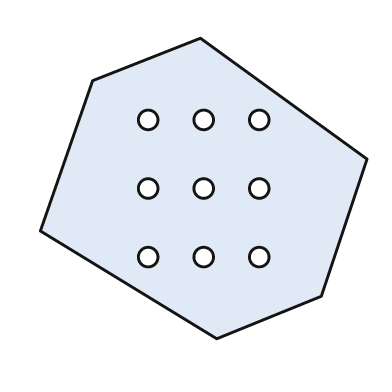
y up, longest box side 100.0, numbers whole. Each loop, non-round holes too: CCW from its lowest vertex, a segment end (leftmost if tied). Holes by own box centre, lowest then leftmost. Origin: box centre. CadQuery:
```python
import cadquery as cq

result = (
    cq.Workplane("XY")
    .moveTo(4.0, -46.0)
    .lineTo(36.0, -33.0)
    .lineTo(50.0, 9.0)
    .lineTo(-1.0, 46.0)
    .lineTo(-34.0, 33.0)
    .lineTo(-50.0, -13.0)
    .close()
    .moveTo(-17.0, -21.0)
    .circle(3.0)
    .moveTo(0.0, -21.0)
    .circle(3.0)
    .moveTo(17.0, -21.0)
    .circle(3.0)
    .moveTo(-17.0, 0.0)
    .circle(3.0)
    .moveTo(0.0, 0.0)
    .circle(3.0)
    .moveTo(17.0, 0.0)
    .circle(3.0)
    .moveTo(-17.0, 21.0)
    .circle(3.0)
    .moveTo(0.0, 21.0)
    .circle(3.0)
    .moveTo(17.0, 21.0)
    .circle(3.0)
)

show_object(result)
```